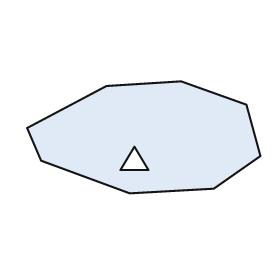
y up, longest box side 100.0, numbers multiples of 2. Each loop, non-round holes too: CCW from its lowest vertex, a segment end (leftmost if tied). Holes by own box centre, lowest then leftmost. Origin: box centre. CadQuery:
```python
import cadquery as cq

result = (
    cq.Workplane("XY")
    .moveTo(-6.0, -24.0)
    .lineTo(30.0, -22.0)
    .lineTo(50.0, -8.0)
    .lineTo(44.0, 14.0)
    .lineTo(16.0, 24.0)
    .lineTo(-16.0, 22.0)
    .lineTo(-50.0, 4.0)
    .lineTo(-44.0, -10.0)
    .close()
    .moveTo(-10.0, -14.0)
    .lineTo(2.0, -14.0)
    .lineTo(-4.0, -4.0)
    .close()
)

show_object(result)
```